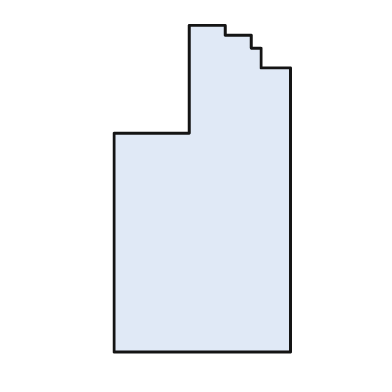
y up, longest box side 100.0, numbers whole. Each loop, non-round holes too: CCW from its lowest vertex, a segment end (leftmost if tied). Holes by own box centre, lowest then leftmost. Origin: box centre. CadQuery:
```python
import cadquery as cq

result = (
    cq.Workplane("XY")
    .moveTo(-27.0, -50.0)
    .lineTo(27.0, -50.0)
    .lineTo(27.0, 37.0)
    .lineTo(18.0, 37.0)
    .lineTo(18.0, 43.0)
    .lineTo(15.0, 43.0)
    .lineTo(15.0, 47.0)
    .lineTo(7.0, 47.0)
    .lineTo(7.0, 50.0)
    .lineTo(-4.0, 50.0)
    .lineTo(-4.0, 17.0)
    .lineTo(-27.0, 17.0)
    .close()
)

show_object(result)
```